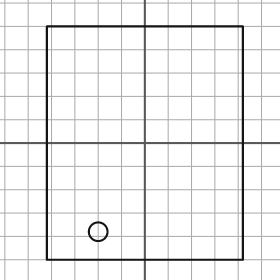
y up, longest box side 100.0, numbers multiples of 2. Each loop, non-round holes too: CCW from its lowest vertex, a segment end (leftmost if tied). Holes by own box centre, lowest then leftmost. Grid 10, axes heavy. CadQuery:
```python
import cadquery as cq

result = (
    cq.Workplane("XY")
    .moveTo(-42.0, -50.0)
    .lineTo(42.0, -50.0)
    .lineTo(42.0, 50.0)
    .lineTo(-42.0, 50.0)
    .close()
    .moveTo(-20.0, -38.0)
    .circle(4.0)
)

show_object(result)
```